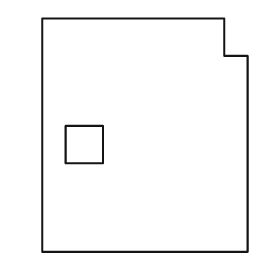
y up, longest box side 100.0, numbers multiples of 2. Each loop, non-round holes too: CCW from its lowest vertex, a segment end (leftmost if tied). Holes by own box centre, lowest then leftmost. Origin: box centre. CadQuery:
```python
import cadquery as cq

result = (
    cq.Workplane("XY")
    .moveTo(-44.0, -50.0)
    .lineTo(44.0, -50.0)
    .lineTo(44.0, 34.0)
    .lineTo(34.0, 34.0)
    .lineTo(34.0, 50.0)
    .lineTo(-44.0, 50.0)
    .close()
    .moveTo(-34.0, -12.0)
    .lineTo(-18.0, -12.0)
    .lineTo(-18.0, 4.0)
    .lineTo(-34.0, 4.0)
    .close()
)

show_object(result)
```